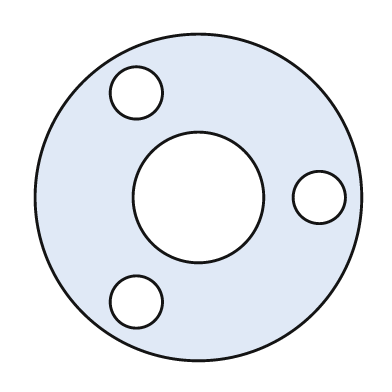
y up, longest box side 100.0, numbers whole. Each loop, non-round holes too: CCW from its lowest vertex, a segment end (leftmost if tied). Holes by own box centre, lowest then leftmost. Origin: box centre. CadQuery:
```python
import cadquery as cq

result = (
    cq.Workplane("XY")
    .moveTo(0.0, 0.0)
    .circle(50.0)
    .moveTo(-19.0, -32.0)
    .circle(8.0)
    .moveTo(0.0, 0.0)
    .circle(20.0)
    .moveTo(37.0, 0.0)
    .circle(8.0)
    .moveTo(-19.0, 32.0)
    .circle(8.0)
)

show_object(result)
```